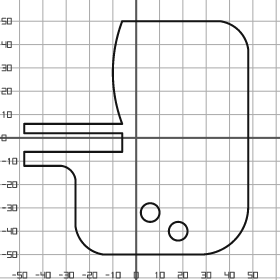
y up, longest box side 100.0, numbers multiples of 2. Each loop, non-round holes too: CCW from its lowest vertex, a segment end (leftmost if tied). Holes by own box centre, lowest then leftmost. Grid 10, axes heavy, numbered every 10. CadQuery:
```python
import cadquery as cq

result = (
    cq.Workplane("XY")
    .moveTo(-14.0, -50.0)
    .lineTo(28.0, -50.0)
    .threePointArc((42.0, -44.0), (48.0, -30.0))
    .lineTo(48.0, 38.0)
    .threePointArc((44.0, 46.0), (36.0, 50.0))
    .lineTo(-6.0, 50.0)
    .threePointArc((-10.0, 28.0), (-6.0, 6.0))
    .lineTo(-48.0, 6.0)
    .lineTo(-48.0, 2.0)
    .lineTo(-6.0, 2.0)
    .lineTo(-6.0, -6.0)
    .lineTo(-48.0, -6.0)
    .lineTo(-48.0, -12.0)
    .lineTo(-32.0, -12.0)
    .threePointArc((-28.0, -14.0), (-26.0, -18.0))
    .lineTo(-26.0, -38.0)
    .threePointArc((-22.0, -46.0), (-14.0, -50.0))
    .close()
    .moveTo(18.0, -40.0)
    .circle(4.0)
    .moveTo(6.0, -32.0)
    .circle(4.0)
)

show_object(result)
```